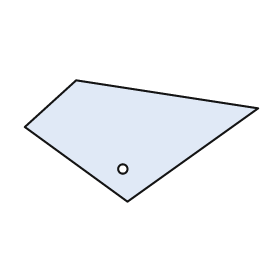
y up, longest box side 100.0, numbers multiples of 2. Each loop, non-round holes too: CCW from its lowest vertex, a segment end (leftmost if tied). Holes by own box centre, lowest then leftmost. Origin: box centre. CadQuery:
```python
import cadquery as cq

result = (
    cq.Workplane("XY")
    .moveTo(-6.0, -26.0)
    .lineTo(50.0, 14.0)
    .lineTo(-28.0, 26.0)
    .lineTo(-50.0, 6.0)
    .close()
    .moveTo(-8.0, -12.0)
    .circle(2.0)
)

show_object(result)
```